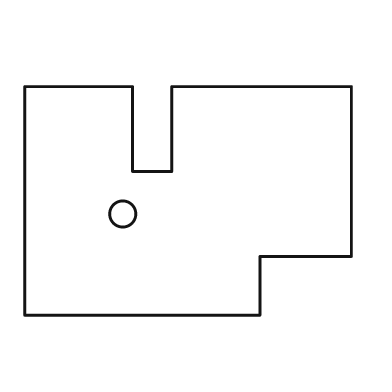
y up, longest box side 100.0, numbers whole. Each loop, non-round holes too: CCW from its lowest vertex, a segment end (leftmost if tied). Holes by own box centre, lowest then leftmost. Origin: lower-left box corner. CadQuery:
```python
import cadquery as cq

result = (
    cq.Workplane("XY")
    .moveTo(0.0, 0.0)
    .lineTo(72.0, 0.0)
    .lineTo(72.0, 18.0)
    .lineTo(100.0, 18.0)
    .lineTo(100.0, 70.0)
    .lineTo(45.0, 70.0)
    .lineTo(45.0, 44.0)
    .lineTo(33.0, 44.0)
    .lineTo(33.0, 70.0)
    .lineTo(0.0, 70.0)
    .close()
    .moveTo(30.0, 31.0)
    .circle(4.0)
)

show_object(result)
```